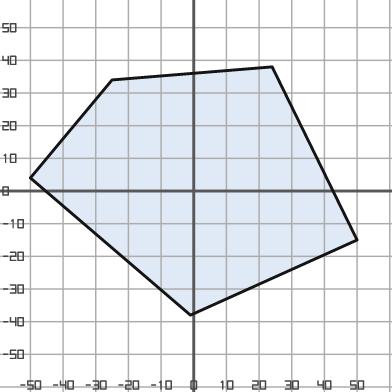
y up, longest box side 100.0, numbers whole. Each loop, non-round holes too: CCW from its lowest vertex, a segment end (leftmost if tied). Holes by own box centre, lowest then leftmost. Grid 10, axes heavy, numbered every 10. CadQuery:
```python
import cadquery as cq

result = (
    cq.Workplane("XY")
    .moveTo(-1.0, -38.0)
    .lineTo(50.0, -15.0)
    .lineTo(24.0, 38.0)
    .lineTo(-25.0, 34.0)
    .lineTo(-50.0, 4.0)
    .close()
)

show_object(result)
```